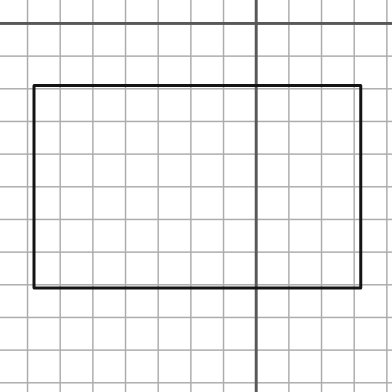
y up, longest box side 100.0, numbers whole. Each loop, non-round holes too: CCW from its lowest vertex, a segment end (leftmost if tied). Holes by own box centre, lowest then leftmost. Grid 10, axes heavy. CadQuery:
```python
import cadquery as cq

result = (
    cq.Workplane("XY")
    .moveTo(-68.0, -81.0)
    .lineTo(32.0, -81.0)
    .lineTo(32.0, -19.0)
    .lineTo(-68.0, -19.0)
    .close()
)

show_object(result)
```